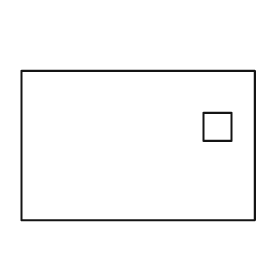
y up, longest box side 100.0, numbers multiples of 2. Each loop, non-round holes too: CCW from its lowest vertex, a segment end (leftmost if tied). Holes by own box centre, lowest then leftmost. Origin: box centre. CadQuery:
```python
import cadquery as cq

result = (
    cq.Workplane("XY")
    .moveTo(-50.0, -32.0)
    .lineTo(50.0, -32.0)
    .lineTo(50.0, 32.0)
    .lineTo(-50.0, 32.0)
    .close()
    .moveTo(28.0, 2.0)
    .lineTo(40.0, 2.0)
    .lineTo(40.0, 14.0)
    .lineTo(28.0, 14.0)
    .close()
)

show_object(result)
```